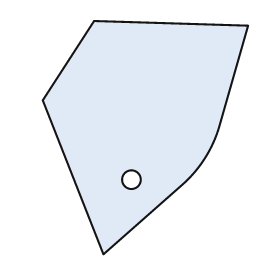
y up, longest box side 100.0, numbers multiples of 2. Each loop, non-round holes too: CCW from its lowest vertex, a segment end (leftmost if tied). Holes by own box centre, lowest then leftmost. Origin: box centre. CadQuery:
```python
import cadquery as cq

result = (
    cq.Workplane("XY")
    .moveTo(-18.0, -50.0)
    .lineTo(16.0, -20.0)
    .threePointArc((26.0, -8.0), (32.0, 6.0))
    .lineTo(44.0, 48.0)
    .lineTo(-22.0, 50.0)
    .lineTo(-44.0, 16.0)
    .close()
    .moveTo(-6.0, -18.0)
    .circle(4.0)
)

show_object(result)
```